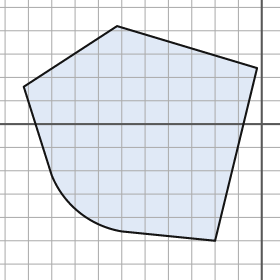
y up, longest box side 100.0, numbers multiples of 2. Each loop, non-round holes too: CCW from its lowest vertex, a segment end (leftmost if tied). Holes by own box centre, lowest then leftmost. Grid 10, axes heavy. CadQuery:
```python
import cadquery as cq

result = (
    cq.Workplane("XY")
    .moveTo(-20.0, -50.0)
    .lineTo(-2.0, 24.0)
    .lineTo(-62.0, 42.0)
    .lineTo(-102.0, 16.0)
    .lineTo(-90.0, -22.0)
    .threePointArc((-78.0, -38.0), (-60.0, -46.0))
    .close()
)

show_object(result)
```